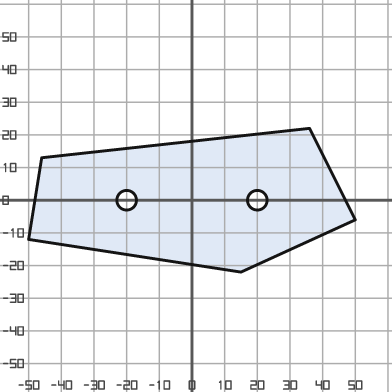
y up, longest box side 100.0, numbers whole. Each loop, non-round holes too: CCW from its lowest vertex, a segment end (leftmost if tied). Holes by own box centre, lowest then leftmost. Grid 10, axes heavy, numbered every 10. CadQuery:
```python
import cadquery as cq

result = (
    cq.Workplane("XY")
    .moveTo(15.0, -22.0)
    .lineTo(50.0, -6.0)
    .lineTo(36.0, 22.0)
    .lineTo(-46.0, 13.0)
    .lineTo(-50.0, -12.0)
    .close()
    .moveTo(-20.0, 0.0)
    .circle(3.0)
    .moveTo(20.0, 0.0)
    .circle(3.0)
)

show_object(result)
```